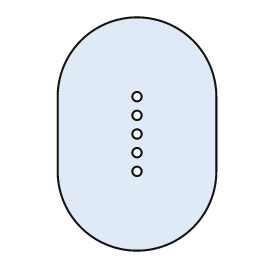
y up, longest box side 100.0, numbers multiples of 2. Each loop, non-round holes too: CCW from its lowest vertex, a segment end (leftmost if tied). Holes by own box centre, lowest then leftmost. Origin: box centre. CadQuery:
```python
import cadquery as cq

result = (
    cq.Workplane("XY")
    .moveTo(-34.0, -16.0)
    .threePointArc((0.0, -50.0), (34.0, -16.0))
    .lineTo(34.0, 16.0)
    .threePointArc((0.0, 50.0), (-34.0, 16.0))
    .close()
    .moveTo(0.0, -16.0)
    .circle(2.0)
    .moveTo(0.0, -8.0)
    .circle(2.0)
    .moveTo(0.0, 0.0)
    .circle(2.0)
    .moveTo(0.0, 8.0)
    .circle(2.0)
    .moveTo(0.0, 16.0)
    .circle(2.0)
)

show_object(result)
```